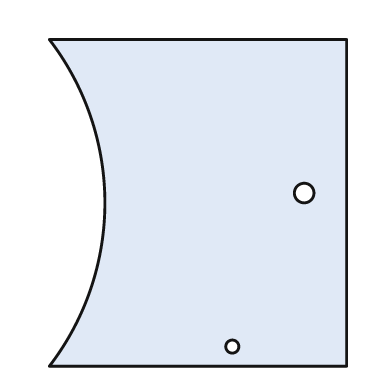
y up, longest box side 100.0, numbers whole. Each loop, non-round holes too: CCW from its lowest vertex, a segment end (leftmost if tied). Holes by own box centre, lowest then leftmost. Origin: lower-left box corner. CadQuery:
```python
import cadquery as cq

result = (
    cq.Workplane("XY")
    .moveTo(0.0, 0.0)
    .lineTo(91.0, 0.0)
    .lineTo(91.0, 100.0)
    .lineTo(0.0, 100.0)
    .threePointArc((17.0, 50.0), (0.0, 0.0))
    .close()
    .moveTo(56.0, 6.0)
    .circle(2.0)
    .moveTo(78.0, 53.0)
    .circle(3.0)
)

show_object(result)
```